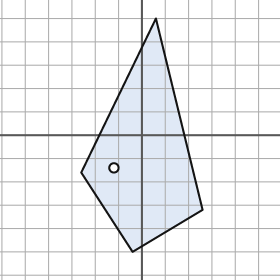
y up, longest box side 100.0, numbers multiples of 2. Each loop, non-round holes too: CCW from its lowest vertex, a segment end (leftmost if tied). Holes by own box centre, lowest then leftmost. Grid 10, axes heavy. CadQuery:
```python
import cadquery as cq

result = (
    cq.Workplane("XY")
    .moveTo(-4.0, -50.0)
    .lineTo(26.0, -32.0)
    .lineTo(6.0, 50.0)
    .lineTo(-26.0, -16.0)
    .close()
    .moveTo(-12.0, -14.0)
    .circle(2.0)
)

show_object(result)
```